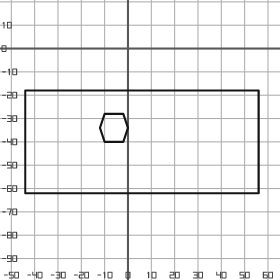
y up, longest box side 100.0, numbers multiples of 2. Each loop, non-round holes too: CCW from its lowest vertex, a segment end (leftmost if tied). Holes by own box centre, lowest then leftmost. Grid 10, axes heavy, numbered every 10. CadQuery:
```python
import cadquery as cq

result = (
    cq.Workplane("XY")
    .moveTo(-44.0, -62.0)
    .lineTo(56.0, -62.0)
    .lineTo(56.0, -18.0)
    .lineTo(-44.0, -18.0)
    .close()
    .moveTo(-10.0, -40.0)
    .lineTo(-2.0, -40.0)
    .lineTo(0.0, -34.0)
    .lineTo(-2.0, -28.0)
    .lineTo(-10.0, -28.0)
    .lineTo(-12.0, -34.0)
    .close()
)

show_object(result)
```